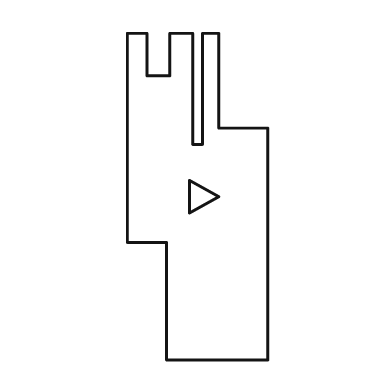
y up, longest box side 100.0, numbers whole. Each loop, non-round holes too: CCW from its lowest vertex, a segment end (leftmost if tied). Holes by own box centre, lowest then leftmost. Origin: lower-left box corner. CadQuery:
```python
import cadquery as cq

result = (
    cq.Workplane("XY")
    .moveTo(12.0, 0.0)
    .lineTo(43.0, 0.0)
    .lineTo(43.0, 71.0)
    .lineTo(28.0, 71.0)
    .lineTo(28.0, 100.0)
    .lineTo(23.0, 100.0)
    .lineTo(23.0, 66.0)
    .lineTo(20.0, 66.0)
    .lineTo(20.0, 100.0)
    .lineTo(13.0, 100.0)
    .lineTo(13.0, 87.0)
    .lineTo(6.0, 87.0)
    .lineTo(6.0, 100.0)
    .lineTo(0.0, 100.0)
    .lineTo(0.0, 36.0)
    .lineTo(12.0, 36.0)
    .close()
    .moveTo(19.0, 45.0)
    .lineTo(28.0, 50.0)
    .lineTo(19.0, 55.0)
    .close()
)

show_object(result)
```